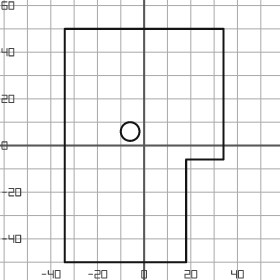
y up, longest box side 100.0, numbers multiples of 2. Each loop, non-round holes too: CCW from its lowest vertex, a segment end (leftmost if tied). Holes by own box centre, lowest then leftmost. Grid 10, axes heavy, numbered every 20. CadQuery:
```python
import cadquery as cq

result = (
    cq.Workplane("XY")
    .moveTo(-34.0, -50.0)
    .lineTo(18.0, -50.0)
    .lineTo(18.0, -6.0)
    .lineTo(34.0, -6.0)
    .lineTo(34.0, 50.0)
    .lineTo(-34.0, 50.0)
    .close()
    .moveTo(-6.0, 6.0)
    .circle(4.0)
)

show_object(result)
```